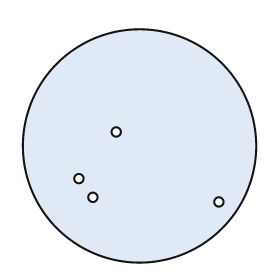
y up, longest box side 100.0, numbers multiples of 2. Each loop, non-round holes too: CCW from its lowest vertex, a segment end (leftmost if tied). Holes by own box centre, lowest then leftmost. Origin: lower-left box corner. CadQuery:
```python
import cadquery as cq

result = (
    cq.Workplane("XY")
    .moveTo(50.0, 50.0)
    .circle(50.0)
    .moveTo(84.0, 26.0)
    .circle(2.0)
    .moveTo(30.0, 28.0)
    .circle(2.0)
    .moveTo(24.0, 36.0)
    .circle(2.0)
    .moveTo(40.0, 56.0)
    .circle(2.0)
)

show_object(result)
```